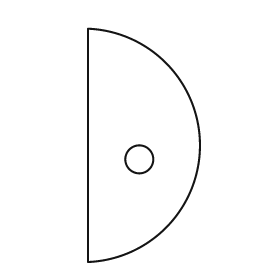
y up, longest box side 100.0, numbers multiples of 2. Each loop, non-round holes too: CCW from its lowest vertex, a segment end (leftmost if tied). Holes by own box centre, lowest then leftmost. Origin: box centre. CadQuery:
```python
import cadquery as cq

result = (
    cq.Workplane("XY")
    .moveTo(-24.0, -50.0)
    .threePointArc((24.0, 0.0), (-24.0, 50.0))
    .close()
    .moveTo(-2.0, -6.0)
    .circle(6.0)
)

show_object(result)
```